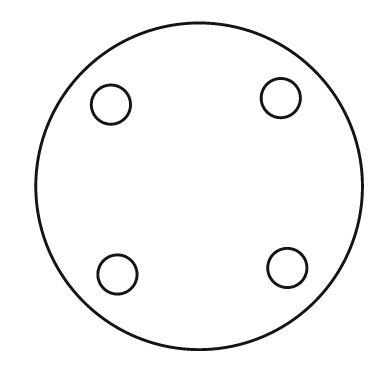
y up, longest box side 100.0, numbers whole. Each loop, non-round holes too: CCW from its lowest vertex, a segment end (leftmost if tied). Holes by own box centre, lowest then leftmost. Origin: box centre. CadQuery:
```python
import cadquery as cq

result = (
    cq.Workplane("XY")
    .moveTo(0.0, 0.0)
    .circle(50.0)
    .moveTo(-25.0, -27.0)
    .circle(6.0)
    .moveTo(27.0, -25.0)
    .circle(6.0)
    .moveTo(-27.0, 25.0)
    .circle(6.0)
    .moveTo(25.0, 27.0)
    .circle(6.0)
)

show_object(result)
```